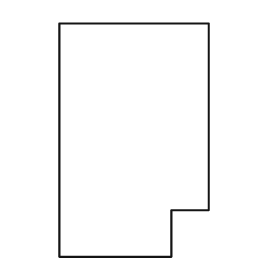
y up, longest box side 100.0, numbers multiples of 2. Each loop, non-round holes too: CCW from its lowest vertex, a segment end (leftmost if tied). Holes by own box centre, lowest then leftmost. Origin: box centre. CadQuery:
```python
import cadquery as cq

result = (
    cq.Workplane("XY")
    .moveTo(-32.0, -50.0)
    .lineTo(16.0, -50.0)
    .lineTo(16.0, -30.0)
    .lineTo(32.0, -30.0)
    .lineTo(32.0, 50.0)
    .lineTo(-32.0, 50.0)
    .close()
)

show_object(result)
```